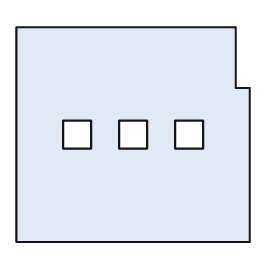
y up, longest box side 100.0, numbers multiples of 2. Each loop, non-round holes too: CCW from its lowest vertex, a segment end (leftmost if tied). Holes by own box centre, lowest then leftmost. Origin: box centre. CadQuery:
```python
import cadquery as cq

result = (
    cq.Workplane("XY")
    .moveTo(-50.0, -46.0)
    .lineTo(50.0, -46.0)
    .lineTo(50.0, 20.0)
    .lineTo(44.0, 20.0)
    .lineTo(44.0, 46.0)
    .lineTo(-50.0, 46.0)
    .close()
    .moveTo(-30.0, -6.0)
    .lineTo(-18.0, -6.0)
    .lineTo(-18.0, 6.0)
    .lineTo(-30.0, 6.0)
    .close()
    .moveTo(-6.0, -6.0)
    .lineTo(6.0, -6.0)
    .lineTo(6.0, 6.0)
    .lineTo(-6.0, 6.0)
    .close()
    .moveTo(18.0, -6.0)
    .lineTo(30.0, -6.0)
    .lineTo(30.0, 6.0)
    .lineTo(18.0, 6.0)
    .close()
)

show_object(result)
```